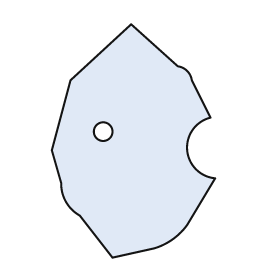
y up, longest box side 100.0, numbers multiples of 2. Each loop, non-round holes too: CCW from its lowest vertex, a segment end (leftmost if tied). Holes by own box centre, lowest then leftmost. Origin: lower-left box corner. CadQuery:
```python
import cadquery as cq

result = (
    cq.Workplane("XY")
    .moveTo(26.0, 0.0)
    .lineTo(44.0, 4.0)
    .threePointArc((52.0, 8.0), (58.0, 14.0))
    .lineTo(70.0, 34.0)
    .threePointArc((58.0, 46.0), (68.0, 60.0))
    .lineTo(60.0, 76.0)
    .threePointArc((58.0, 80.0), (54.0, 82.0))
    .lineTo(34.0, 100.0)
    .lineTo(8.0, 76.0)
    .lineTo(0.0, 46.0)
    .lineTo(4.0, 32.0)
    .threePointArc((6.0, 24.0), (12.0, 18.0))
    .close()
    .moveTo(22.0, 54.0)
    .circle(4.0)
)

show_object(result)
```